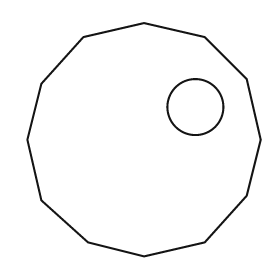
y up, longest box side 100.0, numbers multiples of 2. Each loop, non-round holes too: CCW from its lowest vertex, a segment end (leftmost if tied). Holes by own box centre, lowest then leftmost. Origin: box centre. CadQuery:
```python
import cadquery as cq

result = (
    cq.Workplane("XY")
    .moveTo(0.0, -50.0)
    .lineTo(26.0, -44.0)
    .lineTo(44.0, -24.0)
    .lineTo(50.0, 0.0)
    .lineTo(44.0, 26.0)
    .lineTo(26.0, 44.0)
    .lineTo(0.0, 50.0)
    .lineTo(-26.0, 44.0)
    .lineTo(-44.0, 24.0)
    .lineTo(-50.0, 0.0)
    .lineTo(-44.0, -26.0)
    .lineTo(-24.0, -44.0)
    .close()
    .moveTo(22.0, 14.0)
    .circle(12.0)
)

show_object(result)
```